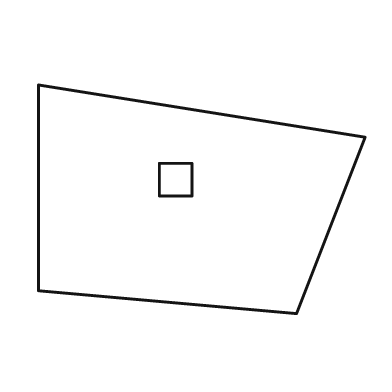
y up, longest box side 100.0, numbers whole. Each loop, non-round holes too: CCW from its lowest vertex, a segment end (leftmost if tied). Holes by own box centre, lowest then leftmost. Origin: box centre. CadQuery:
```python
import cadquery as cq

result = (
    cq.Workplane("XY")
    .moveTo(29.0, -35.0)
    .lineTo(50.0, 19.0)
    .lineTo(-50.0, 35.0)
    .lineTo(-50.0, -28.0)
    .close()
    .moveTo(-13.0, 1.0)
    .lineTo(-3.0, 1.0)
    .lineTo(-3.0, 11.0)
    .lineTo(-13.0, 11.0)
    .close()
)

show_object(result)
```